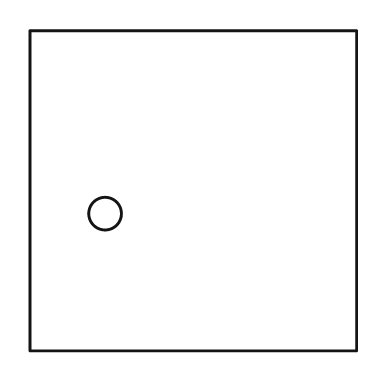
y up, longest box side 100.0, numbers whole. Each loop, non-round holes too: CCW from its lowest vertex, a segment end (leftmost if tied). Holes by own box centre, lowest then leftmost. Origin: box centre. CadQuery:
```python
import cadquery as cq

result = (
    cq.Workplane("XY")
    .moveTo(-50.0, -49.0)
    .lineTo(50.0, -49.0)
    .lineTo(50.0, 49.0)
    .lineTo(-50.0, 49.0)
    .close()
    .moveTo(-27.0, -7.0)
    .circle(5.0)
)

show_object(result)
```